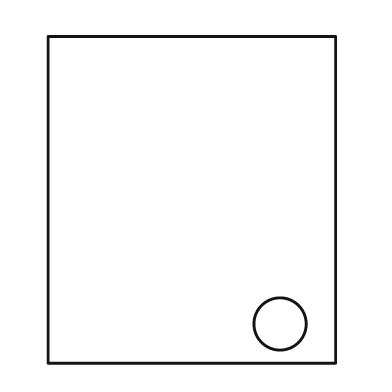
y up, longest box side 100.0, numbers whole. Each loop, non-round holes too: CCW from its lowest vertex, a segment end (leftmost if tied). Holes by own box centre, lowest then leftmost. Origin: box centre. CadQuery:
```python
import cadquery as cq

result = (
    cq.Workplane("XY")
    .moveTo(-44.0, -50.0)
    .lineTo(44.0, -50.0)
    .lineTo(44.0, 50.0)
    .lineTo(-44.0, 50.0)
    .close()
    .moveTo(27.0, -38.0)
    .circle(8.0)
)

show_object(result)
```